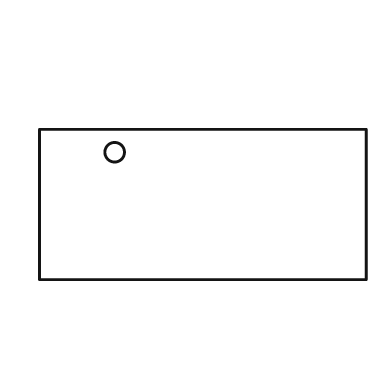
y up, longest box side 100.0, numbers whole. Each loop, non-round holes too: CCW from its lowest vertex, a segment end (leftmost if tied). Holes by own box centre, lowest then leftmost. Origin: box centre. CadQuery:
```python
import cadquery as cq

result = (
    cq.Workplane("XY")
    .moveTo(-50.0, -23.0)
    .lineTo(50.0, -23.0)
    .lineTo(50.0, 23.0)
    .lineTo(-50.0, 23.0)
    .close()
    .moveTo(-27.0, 16.0)
    .circle(3.0)
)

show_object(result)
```